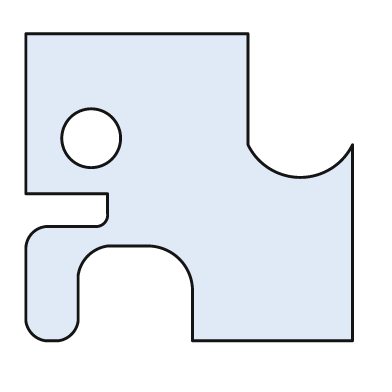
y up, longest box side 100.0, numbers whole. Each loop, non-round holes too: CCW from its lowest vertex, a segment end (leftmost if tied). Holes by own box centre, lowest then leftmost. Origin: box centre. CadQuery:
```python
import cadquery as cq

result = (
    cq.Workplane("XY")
    .moveTo(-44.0, -47.0)
    .lineTo(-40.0, -47.0)
    .threePointArc((-36.0, -45.0), (-34.0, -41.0))
    .lineTo(-34.0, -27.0)
    .threePointArc((-31.0, -21.0), (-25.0, -18.0))
    .lineTo(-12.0, -18.0)
    .threePointArc((-3.0, -22.0), (1.0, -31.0))
    .lineTo(1.0, -47.0)
    .lineTo(50.0, -47.0)
    .lineTo(50.0, 13.0)
    .threePointArc((34.0, 3.0), (18.0, 13.0))
    .lineTo(18.0, 47.0)
    .lineTo(-50.0, 47.0)
    .lineTo(-50.0, -2.0)
    .lineTo(-25.0, -2.0)
    .lineTo(-25.0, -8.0)
    .threePointArc((-26.0, -11.0), (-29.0, -12.0))
    .lineTo(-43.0, -12.0)
    .threePointArc((-48.0, -14.0), (-50.0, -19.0))
    .lineTo(-50.0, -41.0)
    .threePointArc((-48.0, -45.0), (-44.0, -47.0))
    .close()
    .moveTo(-30.0, 15.0)
    .circle(9.0)
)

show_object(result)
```